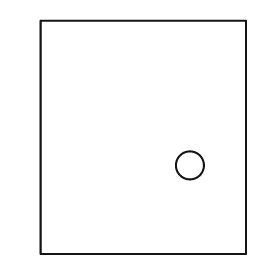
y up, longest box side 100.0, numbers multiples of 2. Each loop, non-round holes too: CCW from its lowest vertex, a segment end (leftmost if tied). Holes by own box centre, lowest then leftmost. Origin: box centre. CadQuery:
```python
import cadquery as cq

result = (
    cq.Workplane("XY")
    .moveTo(-44.0, -50.0)
    .lineTo(44.0, -50.0)
    .lineTo(44.0, 50.0)
    .lineTo(-44.0, 50.0)
    .close()
    .moveTo(20.0, -12.0)
    .circle(6.0)
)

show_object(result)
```